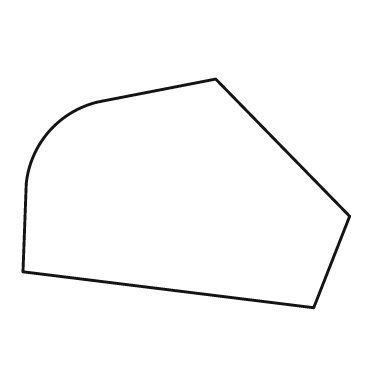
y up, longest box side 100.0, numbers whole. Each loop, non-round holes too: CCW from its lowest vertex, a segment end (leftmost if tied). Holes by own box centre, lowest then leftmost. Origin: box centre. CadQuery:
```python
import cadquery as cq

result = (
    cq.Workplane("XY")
    .moveTo(39.0, -35.0)
    .lineTo(50.0, -7.0)
    .lineTo(9.0, 35.0)
    .lineTo(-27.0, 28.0)
    .threePointArc((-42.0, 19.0), (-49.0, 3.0))
    .lineTo(-50.0, -24.0)
    .close()
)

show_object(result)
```